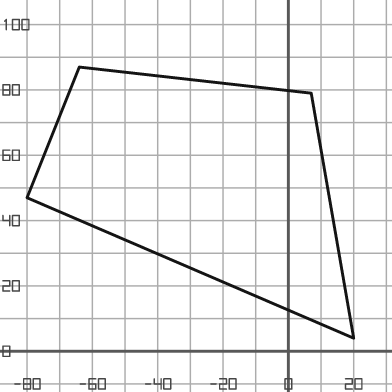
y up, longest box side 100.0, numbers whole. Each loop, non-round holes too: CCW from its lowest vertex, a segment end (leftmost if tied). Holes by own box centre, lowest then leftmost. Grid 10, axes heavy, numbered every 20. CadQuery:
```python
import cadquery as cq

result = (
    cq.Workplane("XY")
    .moveTo(20.0, 4.0)
    .lineTo(7.0, 79.0)
    .lineTo(-64.0, 87.0)
    .lineTo(-80.0, 47.0)
    .close()
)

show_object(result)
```